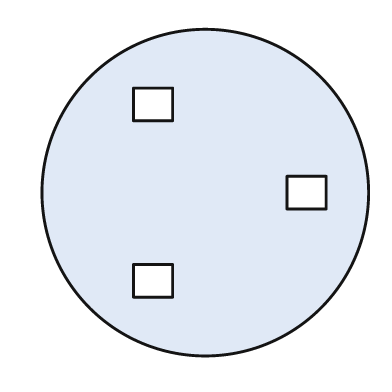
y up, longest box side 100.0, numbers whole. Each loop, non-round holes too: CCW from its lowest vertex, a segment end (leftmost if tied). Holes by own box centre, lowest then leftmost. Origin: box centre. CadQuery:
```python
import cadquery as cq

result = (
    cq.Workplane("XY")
    .moveTo(0.0, 0.0)
    .circle(50.0)
    .moveTo(-22.0, -32.0)
    .lineTo(-10.0, -32.0)
    .lineTo(-10.0, -22.0)
    .lineTo(-22.0, -22.0)
    .close()
    .moveTo(25.0, -5.0)
    .lineTo(37.0, -5.0)
    .lineTo(37.0, 5.0)
    .lineTo(25.0, 5.0)
    .close()
    .moveTo(-22.0, 22.0)
    .lineTo(-10.0, 22.0)
    .lineTo(-10.0, 32.0)
    .lineTo(-22.0, 32.0)
    .close()
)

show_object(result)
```